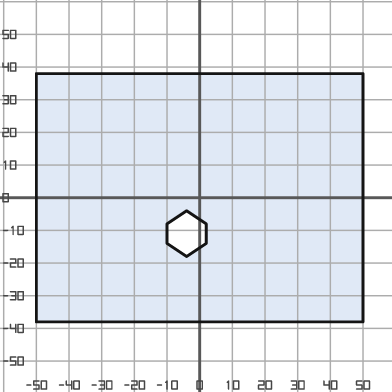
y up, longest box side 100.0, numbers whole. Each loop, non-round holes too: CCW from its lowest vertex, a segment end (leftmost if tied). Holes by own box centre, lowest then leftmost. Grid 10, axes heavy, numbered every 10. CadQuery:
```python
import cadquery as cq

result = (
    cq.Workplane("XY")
    .moveTo(-50.0, -38.0)
    .lineTo(50.0, -38.0)
    .lineTo(50.0, 38.0)
    .lineTo(-50.0, 38.0)
    .close()
    .moveTo(-4.0, -18.0)
    .lineTo(2.0, -14.0)
    .lineTo(2.0, -8.0)
    .lineTo(-4.0, -4.0)
    .lineTo(-10.0, -8.0)
    .lineTo(-10.0, -14.0)
    .close()
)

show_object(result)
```